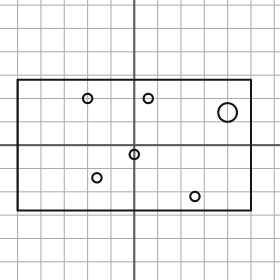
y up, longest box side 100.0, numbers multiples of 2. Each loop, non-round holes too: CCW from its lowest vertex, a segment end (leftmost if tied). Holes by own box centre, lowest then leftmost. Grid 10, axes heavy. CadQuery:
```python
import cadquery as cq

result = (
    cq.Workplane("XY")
    .moveTo(-50.0, -28.0)
    .lineTo(50.0, -28.0)
    .lineTo(50.0, 28.0)
    .lineTo(-50.0, 28.0)
    .close()
    .moveTo(26.0, -22.0)
    .circle(2.0)
    .moveTo(-16.0, -14.0)
    .circle(2.0)
    .moveTo(0.0, -4.0)
    .circle(2.0)
    .moveTo(40.0, 14.0)
    .circle(4.0)
    .moveTo(-20.0, 20.0)
    .circle(2.0)
    .moveTo(6.0, 20.0)
    .circle(2.0)
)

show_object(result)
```